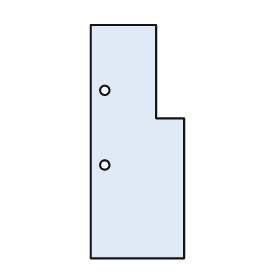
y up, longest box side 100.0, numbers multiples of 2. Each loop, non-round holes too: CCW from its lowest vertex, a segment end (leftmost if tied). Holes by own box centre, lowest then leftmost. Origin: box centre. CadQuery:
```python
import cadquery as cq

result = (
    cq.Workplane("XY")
    .moveTo(-20.0, -50.0)
    .lineTo(20.0, -50.0)
    .lineTo(20.0, 10.0)
    .lineTo(8.0, 10.0)
    .lineTo(8.0, 50.0)
    .lineTo(-20.0, 50.0)
    .close()
    .moveTo(-14.0, -10.0)
    .circle(2.0)
    .moveTo(-14.0, 22.0)
    .circle(2.0)
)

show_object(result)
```